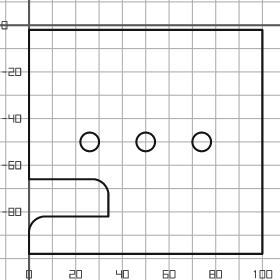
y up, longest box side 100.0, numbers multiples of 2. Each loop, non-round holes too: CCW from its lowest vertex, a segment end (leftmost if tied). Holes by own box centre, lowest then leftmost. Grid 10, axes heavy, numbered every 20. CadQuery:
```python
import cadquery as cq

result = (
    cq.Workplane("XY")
    .moveTo(0.0, -98.0)
    .lineTo(100.0, -98.0)
    .lineTo(100.0, -2.0)
    .lineTo(0.0, -2.0)
    .lineTo(0.0, -66.0)
    .lineTo(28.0, -66.0)
    .threePointArc((32.0, -68.0), (34.0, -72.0))
    .lineTo(34.0, -82.0)
    .lineTo(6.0, -82.0)
    .threePointArc((2.0, -84.0), (0.0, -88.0))
    .close()
    .moveTo(26.0, -50.0)
    .circle(4.0)
    .moveTo(50.0, -50.0)
    .circle(4.0)
    .moveTo(74.0, -50.0)
    .circle(4.0)
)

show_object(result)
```